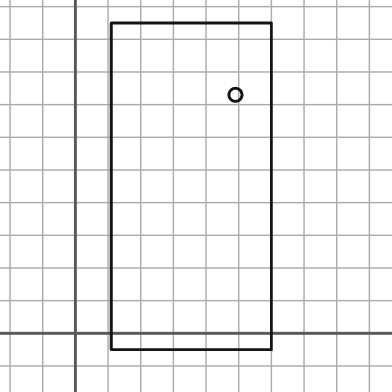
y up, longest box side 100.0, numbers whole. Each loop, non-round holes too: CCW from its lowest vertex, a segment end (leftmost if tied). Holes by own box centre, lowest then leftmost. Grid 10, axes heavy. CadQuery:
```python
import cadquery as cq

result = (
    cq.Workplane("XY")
    .moveTo(11.0, -5.0)
    .lineTo(60.0, -5.0)
    .lineTo(60.0, 95.0)
    .lineTo(11.0, 95.0)
    .close()
    .moveTo(49.0, 73.0)
    .circle(2.0)
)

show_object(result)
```